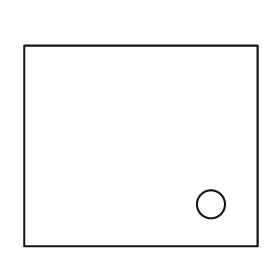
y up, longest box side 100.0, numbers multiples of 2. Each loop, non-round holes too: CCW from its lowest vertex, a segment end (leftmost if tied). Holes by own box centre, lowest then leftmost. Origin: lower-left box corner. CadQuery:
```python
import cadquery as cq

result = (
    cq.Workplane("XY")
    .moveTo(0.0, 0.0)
    .lineTo(100.0, 0.0)
    .lineTo(100.0, 86.0)
    .lineTo(0.0, 86.0)
    .close()
    .moveTo(80.0, 18.0)
    .circle(6.0)
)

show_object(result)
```